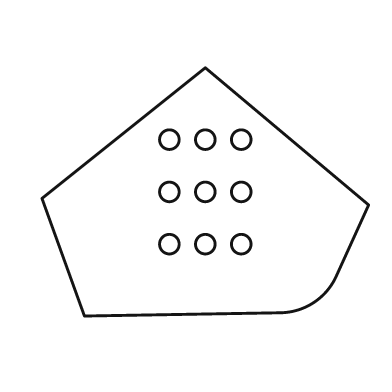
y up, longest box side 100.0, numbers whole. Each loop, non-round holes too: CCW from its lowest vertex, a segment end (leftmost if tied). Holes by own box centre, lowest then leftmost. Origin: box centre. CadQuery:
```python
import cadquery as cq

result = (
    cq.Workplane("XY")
    .moveTo(-37.0, -38.0)
    .lineTo(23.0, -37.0)
    .threePointArc((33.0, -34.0), (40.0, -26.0))
    .lineTo(50.0, -4.0)
    .lineTo(0.0, 38.0)
    .lineTo(-50.0, -2.0)
    .close()
    .moveTo(-11.0, -16.0)
    .circle(3.0)
    .moveTo(0.0, -16.0)
    .circle(3.0)
    .moveTo(11.0, -16.0)
    .circle(3.0)
    .moveTo(-11.0, 0.0)
    .circle(3.0)
    .moveTo(0.0, 0.0)
    .circle(3.0)
    .moveTo(11.0, 0.0)
    .circle(3.0)
    .moveTo(-11.0, 16.0)
    .circle(3.0)
    .moveTo(0.0, 16.0)
    .circle(3.0)
    .moveTo(11.0, 16.0)
    .circle(3.0)
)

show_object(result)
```